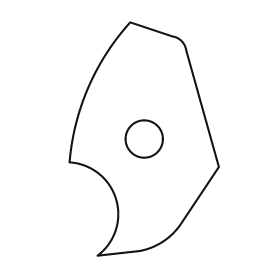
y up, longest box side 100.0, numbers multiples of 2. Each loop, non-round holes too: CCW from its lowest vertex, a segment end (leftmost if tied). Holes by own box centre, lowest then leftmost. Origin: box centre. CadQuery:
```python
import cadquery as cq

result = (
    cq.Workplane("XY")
    .moveTo(-20.0, -50.0)
    .lineTo(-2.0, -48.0)
    .threePointArc((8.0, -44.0), (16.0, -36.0))
    .lineTo(32.0, -12.0)
    .lineTo(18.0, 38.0)
    .threePointArc((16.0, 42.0), (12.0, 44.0))
    .lineTo(-6.0, 50.0)
    .threePointArc((-24.0, 22.0), (-32.0, -10.0))
    .threePointArc((-12.0, -26.0), (-20.0, -50.0))
    .close()
    .moveTo(0.0, 0.0)
    .circle(8.0)
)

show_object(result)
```